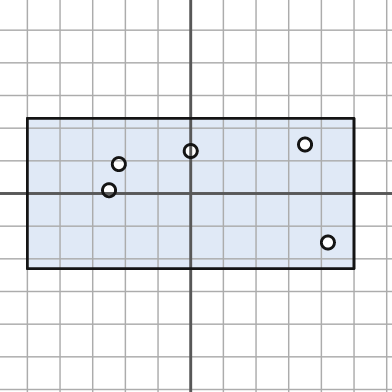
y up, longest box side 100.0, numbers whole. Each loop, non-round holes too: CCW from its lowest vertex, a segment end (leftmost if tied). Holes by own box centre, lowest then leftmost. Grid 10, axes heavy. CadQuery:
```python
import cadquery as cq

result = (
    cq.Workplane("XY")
    .moveTo(-50.0, -23.0)
    .lineTo(50.0, -23.0)
    .lineTo(50.0, 23.0)
    .lineTo(-50.0, 23.0)
    .close()
    .moveTo(42.0, -15.0)
    .circle(2.0)
    .moveTo(-25.0, 1.0)
    .circle(2.0)
    .moveTo(-22.0, 9.0)
    .circle(2.0)
    .moveTo(0.0, 13.0)
    .circle(2.0)
    .moveTo(35.0, 15.0)
    .circle(2.0)
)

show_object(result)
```